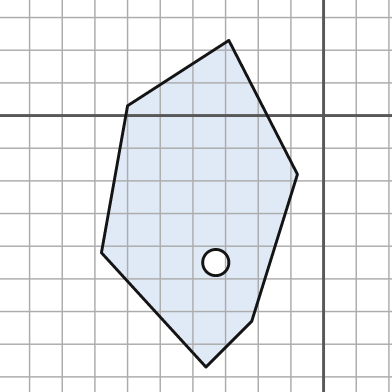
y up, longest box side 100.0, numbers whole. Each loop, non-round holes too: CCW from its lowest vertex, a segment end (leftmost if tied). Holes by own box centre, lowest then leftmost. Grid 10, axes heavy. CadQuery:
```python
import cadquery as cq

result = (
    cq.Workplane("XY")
    .moveTo(-36.0, -77.0)
    .lineTo(-22.0, -63.0)
    .lineTo(-8.0, -18.0)
    .lineTo(-29.0, 23.0)
    .lineTo(-60.0, 3.0)
    .lineTo(-68.0, -42.0)
    .close()
    .moveTo(-33.0, -45.0)
    .circle(4.0)
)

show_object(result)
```